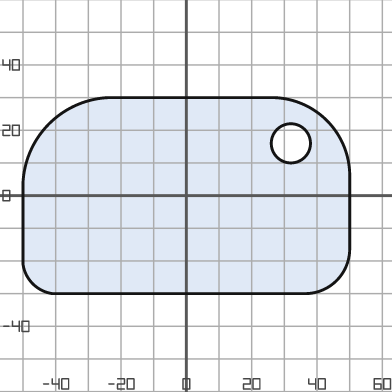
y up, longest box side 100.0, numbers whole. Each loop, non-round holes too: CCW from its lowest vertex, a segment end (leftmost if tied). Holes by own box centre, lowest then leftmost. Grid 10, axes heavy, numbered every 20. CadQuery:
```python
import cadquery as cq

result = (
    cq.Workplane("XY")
    .moveTo(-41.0, -30.0)
    .lineTo(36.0, -30.0)
    .threePointArc((46.0, -26.0), (50.0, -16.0))
    .lineTo(50.0, 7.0)
    .threePointArc((43.0, 23.0), (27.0, 30.0))
    .lineTo(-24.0, 30.0)
    .threePointArc((-42.0, 22.0), (-50.0, 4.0))
    .lineTo(-50.0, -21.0)
    .threePointArc((-47.0, -27.0), (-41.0, -30.0))
    .close()
    .moveTo(32.0, 16.0)
    .circle(6.0)
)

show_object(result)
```